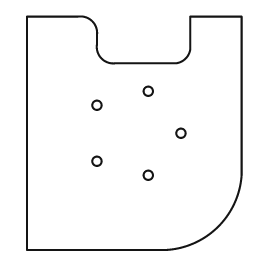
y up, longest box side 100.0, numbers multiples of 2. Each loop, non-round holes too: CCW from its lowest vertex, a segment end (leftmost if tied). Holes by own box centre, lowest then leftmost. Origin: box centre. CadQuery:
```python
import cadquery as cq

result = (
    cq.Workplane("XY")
    .moveTo(-46.0, -50.0)
    .lineTo(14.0, -50.0)
    .threePointArc((36.0, -40.0), (46.0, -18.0))
    .lineTo(46.0, 50.0)
    .lineTo(24.0, 50.0)
    .lineTo(24.0, 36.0)
    .threePointArc((22.0, 32.0), (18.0, 30.0))
    .lineTo(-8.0, 30.0)
    .threePointArc((-14.0, 32.0), (-16.0, 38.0))
    .lineTo(-16.0, 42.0)
    .threePointArc((-18.0, 48.0), (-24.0, 50.0))
    .lineTo(-46.0, 50.0)
    .close()
    .moveTo(6.0, -18.0)
    .circle(2.0)
    .moveTo(-16.0, -12.0)
    .circle(2.0)
    .moveTo(20.0, 0.0)
    .circle(2.0)
    .moveTo(-16.0, 12.0)
    .circle(2.0)
    .moveTo(6.0, 18.0)
    .circle(2.0)
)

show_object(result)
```